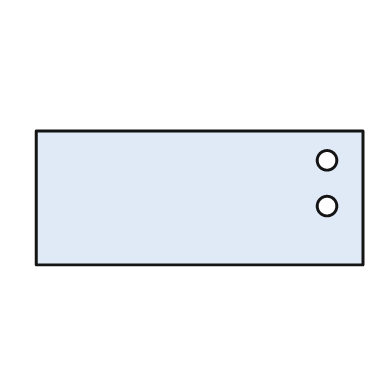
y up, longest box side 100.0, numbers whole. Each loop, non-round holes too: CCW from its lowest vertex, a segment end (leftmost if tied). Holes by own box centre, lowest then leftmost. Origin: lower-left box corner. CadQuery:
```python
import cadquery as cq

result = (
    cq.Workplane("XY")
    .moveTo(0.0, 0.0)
    .lineTo(100.0, 0.0)
    .lineTo(100.0, 41.0)
    .lineTo(0.0, 41.0)
    .close()
    .moveTo(89.0, 18.0)
    .circle(3.0)
    .moveTo(89.0, 32.0)
    .circle(3.0)
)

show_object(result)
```